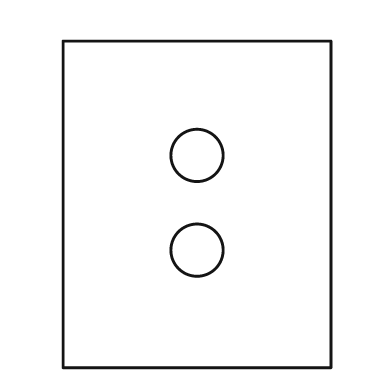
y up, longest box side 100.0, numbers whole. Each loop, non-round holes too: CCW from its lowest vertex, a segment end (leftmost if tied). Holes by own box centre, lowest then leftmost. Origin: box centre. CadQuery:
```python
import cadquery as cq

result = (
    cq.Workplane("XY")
    .moveTo(-41.0, -50.0)
    .lineTo(41.0, -50.0)
    .lineTo(41.0, 50.0)
    .lineTo(-41.0, 50.0)
    .close()
    .moveTo(0.0, -14.0)
    .circle(8.0)
    .moveTo(0.0, 15.0)
    .circle(8.0)
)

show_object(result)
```